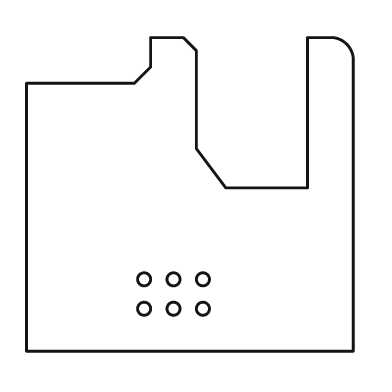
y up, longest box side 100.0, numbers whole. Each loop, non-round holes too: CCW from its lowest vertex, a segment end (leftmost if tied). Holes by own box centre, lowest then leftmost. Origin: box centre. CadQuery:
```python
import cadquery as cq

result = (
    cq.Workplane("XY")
    .moveTo(-50.0, -48.0)
    .lineTo(50.0, -48.0)
    .lineTo(50.0, 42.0)
    .threePointArc((48.0, 46.0), (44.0, 48.0))
    .lineTo(36.0, 48.0)
    .lineTo(36.0, 2.0)
    .lineTo(11.0, 2.0)
    .lineTo(2.0, 14.0)
    .lineTo(2.0, 44.0)
    .lineTo(-2.0, 48.0)
    .lineTo(-12.0, 48.0)
    .lineTo(-12.0, 39.0)
    .lineTo(-17.0, 34.0)
    .lineTo(-50.0, 34.0)
    .close()
    .moveTo(-14.0, -35.0)
    .circle(2.0)
    .moveTo(-5.0, -35.0)
    .circle(2.0)
    .moveTo(4.0, -35.0)
    .circle(2.0)
    .moveTo(-14.0, -26.0)
    .circle(2.0)
    .moveTo(-5.0, -26.0)
    .circle(2.0)
    .moveTo(4.0, -26.0)
    .circle(2.0)
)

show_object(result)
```